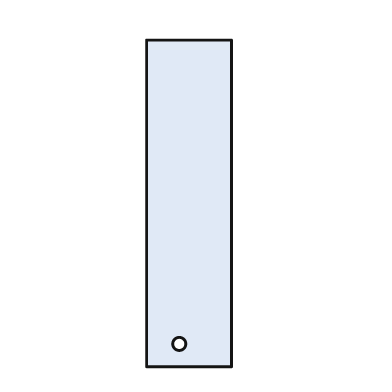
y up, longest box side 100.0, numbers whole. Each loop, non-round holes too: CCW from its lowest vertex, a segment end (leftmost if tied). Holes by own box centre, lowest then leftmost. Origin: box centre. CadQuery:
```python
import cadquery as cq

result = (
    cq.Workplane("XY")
    .moveTo(-13.0, -50.0)
    .lineTo(13.0, -50.0)
    .lineTo(13.0, 50.0)
    .lineTo(-13.0, 50.0)
    .close()
    .moveTo(-3.0, -43.0)
    .circle(2.0)
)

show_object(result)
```